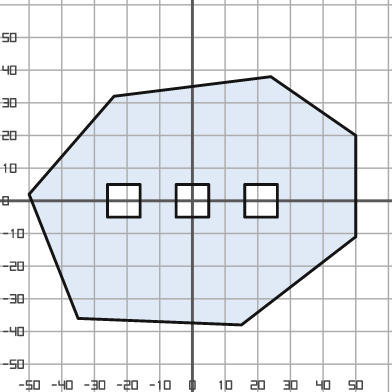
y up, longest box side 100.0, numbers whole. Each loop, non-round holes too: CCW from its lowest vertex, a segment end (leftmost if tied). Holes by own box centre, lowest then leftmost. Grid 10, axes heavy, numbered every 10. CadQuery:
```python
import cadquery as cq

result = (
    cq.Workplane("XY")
    .moveTo(15.0, -38.0)
    .lineTo(50.0, -11.0)
    .lineTo(50.0, 20.0)
    .lineTo(24.0, 38.0)
    .lineTo(-24.0, 32.0)
    .lineTo(-50.0, 2.0)
    .lineTo(-35.0, -36.0)
    .close()
    .moveTo(-26.0, -5.0)
    .lineTo(-16.0, -5.0)
    .lineTo(-16.0, 5.0)
    .lineTo(-26.0, 5.0)
    .close()
    .moveTo(-5.0, -5.0)
    .lineTo(5.0, -5.0)
    .lineTo(5.0, 5.0)
    .lineTo(-5.0, 5.0)
    .close()
    .moveTo(16.0, -5.0)
    .lineTo(26.0, -5.0)
    .lineTo(26.0, 5.0)
    .lineTo(16.0, 5.0)
    .close()
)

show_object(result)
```